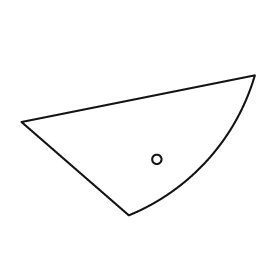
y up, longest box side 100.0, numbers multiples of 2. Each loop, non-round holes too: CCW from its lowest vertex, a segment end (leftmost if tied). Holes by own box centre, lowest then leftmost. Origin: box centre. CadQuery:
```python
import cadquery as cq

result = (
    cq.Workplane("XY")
    .moveTo(-4.0, -30.0)
    .threePointArc((30.0, -6.0), (50.0, 30.0))
    .lineTo(-50.0, 10.0)
    .close()
    .moveTo(8.0, -6.0)
    .circle(2.0)
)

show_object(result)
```